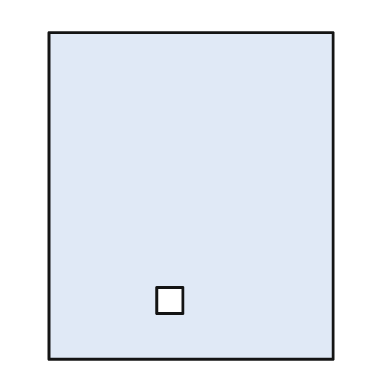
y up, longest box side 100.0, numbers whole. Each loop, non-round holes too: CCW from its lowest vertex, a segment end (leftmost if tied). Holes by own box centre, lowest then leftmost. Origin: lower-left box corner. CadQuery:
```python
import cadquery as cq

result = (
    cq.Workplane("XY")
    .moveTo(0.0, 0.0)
    .lineTo(87.0, 0.0)
    .lineTo(87.0, 100.0)
    .lineTo(0.0, 100.0)
    .close()
    .moveTo(33.0, 14.0)
    .lineTo(41.0, 14.0)
    .lineTo(41.0, 22.0)
    .lineTo(33.0, 22.0)
    .close()
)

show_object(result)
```